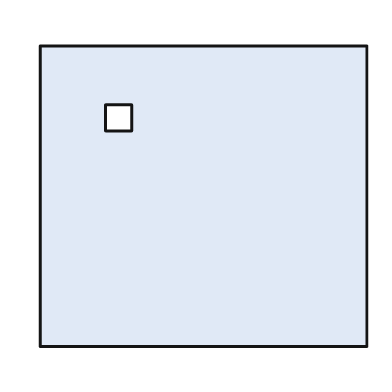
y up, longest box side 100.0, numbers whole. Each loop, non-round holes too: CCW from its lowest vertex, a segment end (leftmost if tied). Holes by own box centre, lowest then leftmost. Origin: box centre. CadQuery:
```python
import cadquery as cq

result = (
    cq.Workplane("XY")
    .moveTo(-50.0, -46.0)
    .lineTo(50.0, -46.0)
    .lineTo(50.0, 46.0)
    .lineTo(-50.0, 46.0)
    .close()
    .moveTo(-30.0, 20.0)
    .lineTo(-22.0, 20.0)
    .lineTo(-22.0, 28.0)
    .lineTo(-30.0, 28.0)
    .close()
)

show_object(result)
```